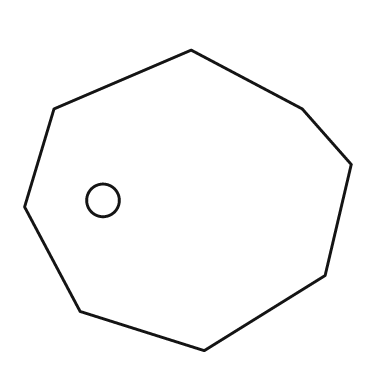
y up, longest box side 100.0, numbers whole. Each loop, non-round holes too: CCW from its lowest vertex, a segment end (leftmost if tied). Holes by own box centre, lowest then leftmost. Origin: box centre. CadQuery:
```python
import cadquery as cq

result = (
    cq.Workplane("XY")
    .moveTo(5.0, -46.0)
    .lineTo(42.0, -23.0)
    .lineTo(50.0, 11.0)
    .lineTo(35.0, 28.0)
    .lineTo(1.0, 46.0)
    .lineTo(-41.0, 28.0)
    .lineTo(-50.0, -2.0)
    .lineTo(-33.0, -34.0)
    .close()
    .moveTo(-26.0, 0.0)
    .circle(5.0)
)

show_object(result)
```